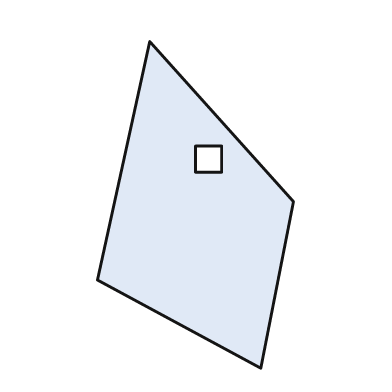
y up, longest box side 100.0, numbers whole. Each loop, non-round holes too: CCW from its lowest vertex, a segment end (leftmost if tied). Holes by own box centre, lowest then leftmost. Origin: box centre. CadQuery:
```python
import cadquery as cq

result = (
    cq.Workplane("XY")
    .moveTo(20.0, -50.0)
    .lineTo(30.0, 1.0)
    .lineTo(-14.0, 50.0)
    .lineTo(-30.0, -23.0)
    .close()
    .moveTo(0.0, 10.0)
    .lineTo(8.0, 10.0)
    .lineTo(8.0, 18.0)
    .lineTo(0.0, 18.0)
    .close()
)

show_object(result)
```